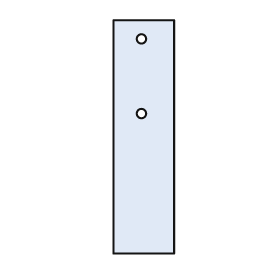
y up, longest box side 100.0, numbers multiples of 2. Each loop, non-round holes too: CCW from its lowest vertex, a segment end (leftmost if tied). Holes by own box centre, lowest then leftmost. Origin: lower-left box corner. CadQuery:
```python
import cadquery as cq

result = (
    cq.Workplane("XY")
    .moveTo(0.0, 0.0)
    .lineTo(26.0, 0.0)
    .lineTo(26.0, 100.0)
    .lineTo(0.0, 100.0)
    .close()
    .moveTo(12.0, 60.0)
    .circle(2.0)
    .moveTo(12.0, 92.0)
    .circle(2.0)
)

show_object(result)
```